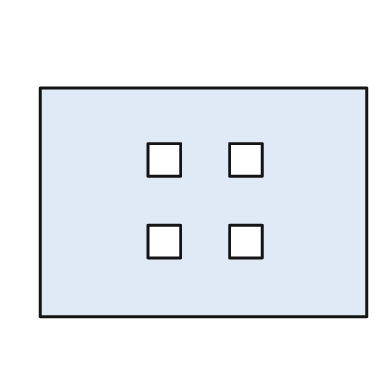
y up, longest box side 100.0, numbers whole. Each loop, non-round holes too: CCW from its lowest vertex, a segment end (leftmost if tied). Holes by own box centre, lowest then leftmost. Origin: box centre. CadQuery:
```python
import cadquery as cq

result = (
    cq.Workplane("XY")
    .moveTo(-50.0, -35.0)
    .lineTo(50.0, -35.0)
    .lineTo(50.0, 35.0)
    .lineTo(-50.0, 35.0)
    .close()
    .moveTo(-17.0, -17.0)
    .lineTo(-7.0, -17.0)
    .lineTo(-7.0, -7.0)
    .lineTo(-17.0, -7.0)
    .close()
    .moveTo(8.0, -17.0)
    .lineTo(18.0, -17.0)
    .lineTo(18.0, -7.0)
    .lineTo(8.0, -7.0)
    .close()
    .moveTo(-17.0, 8.0)
    .lineTo(-7.0, 8.0)
    .lineTo(-7.0, 18.0)
    .lineTo(-17.0, 18.0)
    .close()
    .moveTo(8.0, 8.0)
    .lineTo(18.0, 8.0)
    .lineTo(18.0, 18.0)
    .lineTo(8.0, 18.0)
    .close()
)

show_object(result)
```